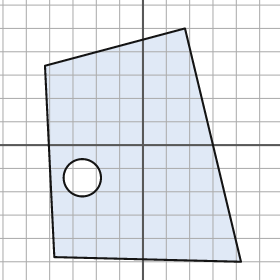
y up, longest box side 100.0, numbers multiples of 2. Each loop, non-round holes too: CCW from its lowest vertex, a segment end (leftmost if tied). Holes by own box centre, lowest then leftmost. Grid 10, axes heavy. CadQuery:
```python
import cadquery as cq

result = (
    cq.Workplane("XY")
    .moveTo(42.0, -50.0)
    .lineTo(18.0, 50.0)
    .lineTo(-42.0, 34.0)
    .lineTo(-38.0, -48.0)
    .close()
    .moveTo(-26.0, -14.0)
    .circle(8.0)
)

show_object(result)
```